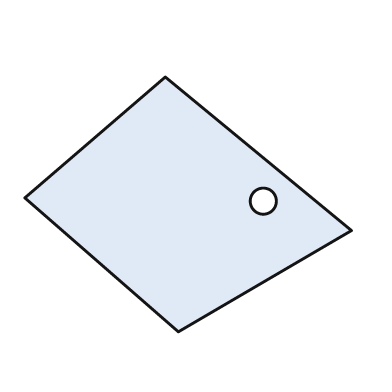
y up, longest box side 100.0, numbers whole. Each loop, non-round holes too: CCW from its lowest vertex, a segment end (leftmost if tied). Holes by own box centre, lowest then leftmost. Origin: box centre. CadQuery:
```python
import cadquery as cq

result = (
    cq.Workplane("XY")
    .moveTo(-3.0, -39.0)
    .lineTo(50.0, -8.0)
    .lineTo(-7.0, 39.0)
    .lineTo(-50.0, 2.0)
    .close()
    .moveTo(23.0, 1.0)
    .circle(4.0)
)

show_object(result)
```